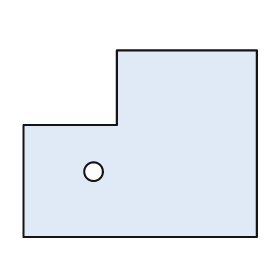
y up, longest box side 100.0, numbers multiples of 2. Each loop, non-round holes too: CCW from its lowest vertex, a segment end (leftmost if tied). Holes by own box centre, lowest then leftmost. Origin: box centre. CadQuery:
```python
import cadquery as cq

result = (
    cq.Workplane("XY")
    .moveTo(-50.0, -40.0)
    .lineTo(50.0, -40.0)
    .lineTo(50.0, 40.0)
    .lineTo(-10.0, 40.0)
    .lineTo(-10.0, 8.0)
    .lineTo(-50.0, 8.0)
    .close()
    .moveTo(-20.0, -12.0)
    .circle(4.0)
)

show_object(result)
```